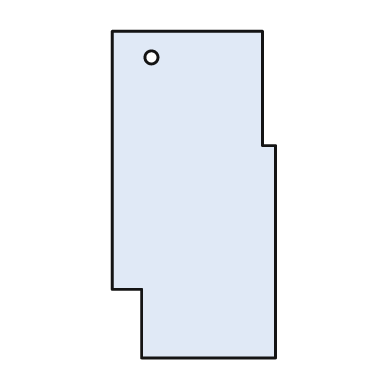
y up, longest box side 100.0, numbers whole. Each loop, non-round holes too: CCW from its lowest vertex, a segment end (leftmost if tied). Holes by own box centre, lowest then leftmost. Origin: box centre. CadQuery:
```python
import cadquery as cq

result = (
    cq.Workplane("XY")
    .moveTo(-16.0, -50.0)
    .lineTo(25.0, -50.0)
    .lineTo(25.0, 15.0)
    .lineTo(21.0, 15.0)
    .lineTo(21.0, 50.0)
    .lineTo(-25.0, 50.0)
    .lineTo(-25.0, -29.0)
    .lineTo(-16.0, -29.0)
    .close()
    .moveTo(-13.0, 42.0)
    .circle(2.0)
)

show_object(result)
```